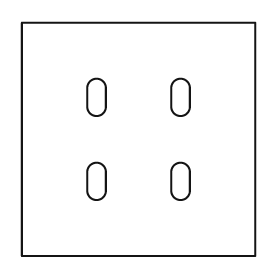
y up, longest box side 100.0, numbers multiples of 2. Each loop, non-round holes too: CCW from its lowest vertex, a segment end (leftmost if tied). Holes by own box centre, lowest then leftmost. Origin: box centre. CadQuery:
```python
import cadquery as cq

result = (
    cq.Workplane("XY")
    .moveTo(-50.0, -50.0)
    .lineTo(50.0, -50.0)
    .lineTo(50.0, 50.0)
    .lineTo(-50.0, 50.0)
    .close()
    .moveTo(-22.0, -22.0)
    .threePointArc((-18.0, -26.0), (-14.0, -22.0))
    .lineTo(-14.0, -14.0)
    .threePointArc((-18.0, -10.0), (-22.0, -14.0))
    .close()
    .moveTo(14.0, -22.0)
    .threePointArc((18.0, -26.0), (22.0, -22.0))
    .lineTo(22.0, -14.0)
    .threePointArc((18.0, -10.0), (14.0, -14.0))
    .close()
    .moveTo(-22.0, 14.0)
    .threePointArc((-18.0, 10.0), (-14.0, 14.0))
    .lineTo(-14.0, 22.0)
    .threePointArc((-18.0, 26.0), (-22.0, 22.0))
    .close()
    .moveTo(14.0, 14.0)
    .threePointArc((18.0, 10.0), (22.0, 14.0))
    .lineTo(22.0, 22.0)
    .threePointArc((18.0, 26.0), (14.0, 22.0))
    .close()
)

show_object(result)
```